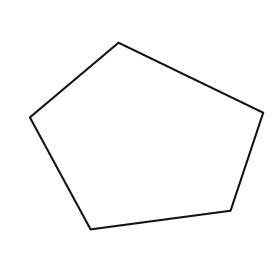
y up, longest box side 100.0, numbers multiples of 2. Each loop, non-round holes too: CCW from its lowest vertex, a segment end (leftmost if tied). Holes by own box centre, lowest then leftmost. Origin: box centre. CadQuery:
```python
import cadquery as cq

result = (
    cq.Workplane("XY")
    .moveTo(-24.0, -40.0)
    .lineTo(36.0, -32.0)
    .lineTo(50.0, 10.0)
    .lineTo(-12.0, 40.0)
    .lineTo(-50.0, 8.0)
    .close()
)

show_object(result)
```